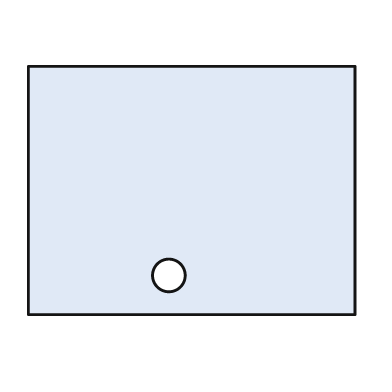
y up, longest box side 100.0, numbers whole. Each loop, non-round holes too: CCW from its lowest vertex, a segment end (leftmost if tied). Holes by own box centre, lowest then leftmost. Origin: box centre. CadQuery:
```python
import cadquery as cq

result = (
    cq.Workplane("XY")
    .moveTo(-50.0, -38.0)
    .lineTo(50.0, -38.0)
    .lineTo(50.0, 38.0)
    .lineTo(-50.0, 38.0)
    .close()
    .moveTo(-7.0, -26.0)
    .circle(5.0)
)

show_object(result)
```